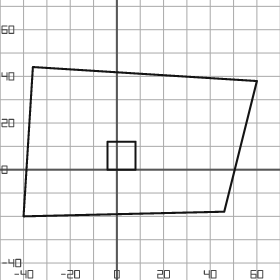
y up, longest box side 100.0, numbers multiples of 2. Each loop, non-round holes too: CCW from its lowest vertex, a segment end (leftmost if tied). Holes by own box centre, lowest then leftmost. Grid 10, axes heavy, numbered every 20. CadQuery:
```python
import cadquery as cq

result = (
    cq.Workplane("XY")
    .moveTo(-40.0, -20.0)
    .lineTo(46.0, -18.0)
    .lineTo(60.0, 38.0)
    .lineTo(-36.0, 44.0)
    .close()
    .moveTo(-4.0, 0.0)
    .lineTo(8.0, 0.0)
    .lineTo(8.0, 12.0)
    .lineTo(-4.0, 12.0)
    .close()
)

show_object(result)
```